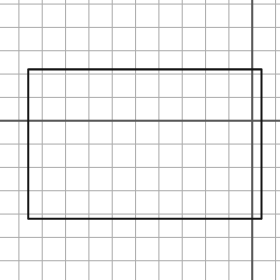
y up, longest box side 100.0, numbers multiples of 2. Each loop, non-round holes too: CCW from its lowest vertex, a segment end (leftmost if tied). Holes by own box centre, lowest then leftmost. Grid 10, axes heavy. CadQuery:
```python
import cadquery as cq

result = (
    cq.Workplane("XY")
    .moveTo(-96.0, -42.0)
    .lineTo(4.0, -42.0)
    .lineTo(4.0, 22.0)
    .lineTo(-96.0, 22.0)
    .close()
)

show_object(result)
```